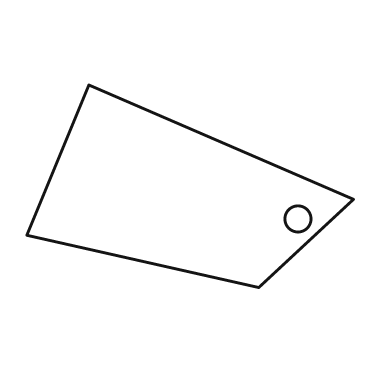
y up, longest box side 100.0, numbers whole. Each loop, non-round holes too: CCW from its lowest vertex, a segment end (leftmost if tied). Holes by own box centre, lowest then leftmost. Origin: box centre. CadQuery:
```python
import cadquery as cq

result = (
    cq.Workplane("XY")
    .moveTo(21.0, -31.0)
    .lineTo(50.0, -4.0)
    .lineTo(-31.0, 31.0)
    .lineTo(-50.0, -15.0)
    .close()
    .moveTo(33.0, -10.0)
    .circle(4.0)
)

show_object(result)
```